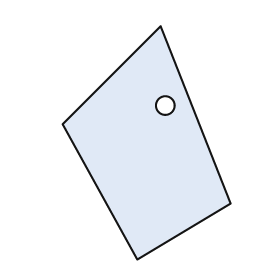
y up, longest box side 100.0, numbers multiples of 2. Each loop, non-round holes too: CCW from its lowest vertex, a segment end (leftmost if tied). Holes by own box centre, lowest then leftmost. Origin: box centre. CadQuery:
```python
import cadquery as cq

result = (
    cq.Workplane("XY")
    .moveTo(-4.0, -50.0)
    .lineTo(36.0, -26.0)
    .lineTo(6.0, 50.0)
    .lineTo(-36.0, 8.0)
    .close()
    .moveTo(8.0, 16.0)
    .circle(4.0)
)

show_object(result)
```